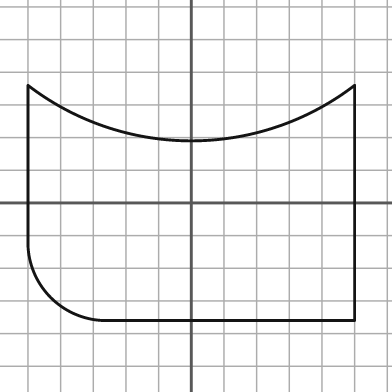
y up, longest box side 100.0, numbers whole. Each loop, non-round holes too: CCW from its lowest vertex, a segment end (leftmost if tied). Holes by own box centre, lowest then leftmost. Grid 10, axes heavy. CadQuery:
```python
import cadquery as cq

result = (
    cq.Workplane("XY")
    .moveTo(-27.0, -36.0)
    .lineTo(50.0, -36.0)
    .lineTo(50.0, 36.0)
    .threePointArc((0.0, 19.0), (-50.0, 36.0))
    .lineTo(-50.0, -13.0)
    .threePointArc((-43.0, -29.0), (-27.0, -36.0))
    .close()
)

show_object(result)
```